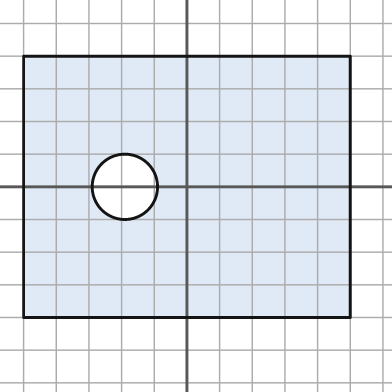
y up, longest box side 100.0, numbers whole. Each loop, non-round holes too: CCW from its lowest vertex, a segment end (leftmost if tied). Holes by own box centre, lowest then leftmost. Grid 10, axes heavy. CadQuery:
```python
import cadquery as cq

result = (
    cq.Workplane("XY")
    .moveTo(-50.0, -40.0)
    .lineTo(50.0, -40.0)
    .lineTo(50.0, 40.0)
    .lineTo(-50.0, 40.0)
    .close()
    .moveTo(-19.0, 0.0)
    .circle(10.0)
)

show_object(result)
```